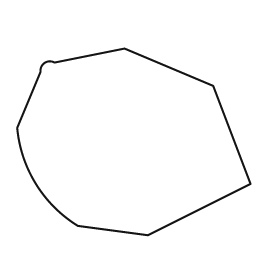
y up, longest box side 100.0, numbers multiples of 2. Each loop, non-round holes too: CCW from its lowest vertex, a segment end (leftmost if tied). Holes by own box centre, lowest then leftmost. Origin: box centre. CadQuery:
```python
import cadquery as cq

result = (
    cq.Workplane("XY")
    .moveTo(6.0, -40.0)
    .lineTo(50.0, -18.0)
    .lineTo(34.0, 24.0)
    .lineTo(-4.0, 40.0)
    .lineTo(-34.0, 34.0)
    .threePointArc((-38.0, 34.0), (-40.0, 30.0))
    .lineTo(-50.0, 6.0)
    .threePointArc((-42.0, -18.0), (-24.0, -36.0))
    .close()
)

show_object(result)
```